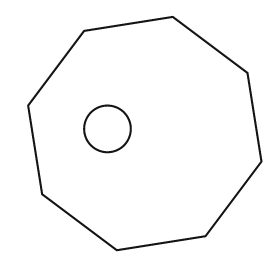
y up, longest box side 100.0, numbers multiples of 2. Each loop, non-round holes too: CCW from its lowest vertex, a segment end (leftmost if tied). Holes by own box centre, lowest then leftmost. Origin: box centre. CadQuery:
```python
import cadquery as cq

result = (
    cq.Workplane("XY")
    .moveTo(-12.0, -50.0)
    .lineTo(26.0, -44.0)
    .lineTo(50.0, -12.0)
    .lineTo(44.0, 26.0)
    .lineTo(12.0, 50.0)
    .lineTo(-26.0, 44.0)
    .lineTo(-50.0, 12.0)
    .lineTo(-44.0, -26.0)
    .close()
    .moveTo(-16.0, 2.0)
    .circle(10.0)
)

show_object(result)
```